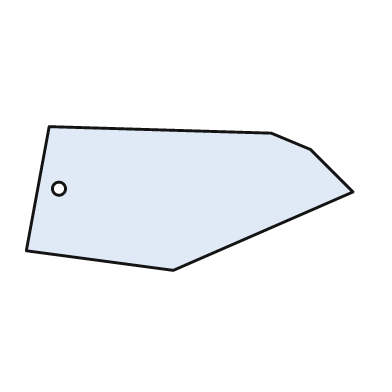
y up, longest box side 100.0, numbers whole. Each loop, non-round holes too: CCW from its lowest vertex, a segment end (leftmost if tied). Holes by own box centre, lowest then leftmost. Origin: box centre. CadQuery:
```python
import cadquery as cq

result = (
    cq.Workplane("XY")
    .moveTo(-5.0, -22.0)
    .lineTo(50.0, 2.0)
    .lineTo(37.0, 15.0)
    .lineTo(25.0, 20.0)
    .lineTo(-43.0, 22.0)
    .lineTo(-50.0, -16.0)
    .close()
    .moveTo(-40.0, 3.0)
    .circle(2.0)
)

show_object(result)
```